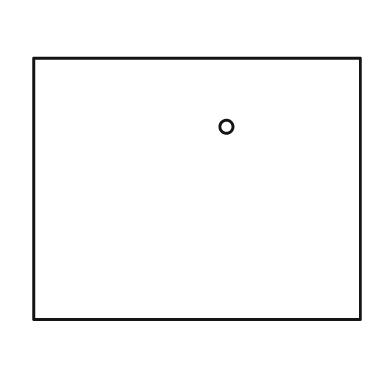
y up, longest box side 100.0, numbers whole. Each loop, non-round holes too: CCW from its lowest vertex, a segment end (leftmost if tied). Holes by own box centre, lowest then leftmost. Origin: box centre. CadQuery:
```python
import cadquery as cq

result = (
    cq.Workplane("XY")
    .moveTo(-50.0, -40.0)
    .lineTo(50.0, -40.0)
    .lineTo(50.0, 40.0)
    .lineTo(-50.0, 40.0)
    .close()
    .moveTo(9.0, 19.0)
    .circle(2.0)
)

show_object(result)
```